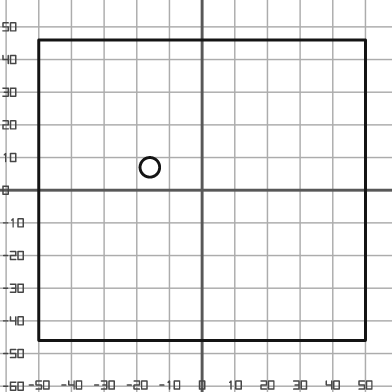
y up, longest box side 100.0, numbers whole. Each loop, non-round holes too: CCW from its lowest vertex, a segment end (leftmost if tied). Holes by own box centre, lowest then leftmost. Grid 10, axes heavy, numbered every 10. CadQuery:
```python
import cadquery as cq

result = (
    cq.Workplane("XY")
    .moveTo(-50.0, -46.0)
    .lineTo(50.0, -46.0)
    .lineTo(50.0, 46.0)
    .lineTo(-50.0, 46.0)
    .close()
    .moveTo(-16.0, 7.0)
    .circle(3.0)
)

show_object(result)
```